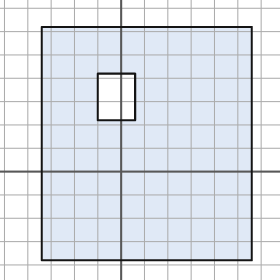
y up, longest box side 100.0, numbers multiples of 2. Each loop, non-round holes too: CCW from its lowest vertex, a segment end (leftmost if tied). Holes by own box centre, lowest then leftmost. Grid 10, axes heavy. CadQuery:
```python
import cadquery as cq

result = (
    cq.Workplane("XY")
    .moveTo(-34.0, -38.0)
    .lineTo(56.0, -38.0)
    .lineTo(56.0, 62.0)
    .lineTo(-34.0, 62.0)
    .close()
    .moveTo(-10.0, 22.0)
    .lineTo(6.0, 22.0)
    .lineTo(6.0, 42.0)
    .lineTo(-10.0, 42.0)
    .close()
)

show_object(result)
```